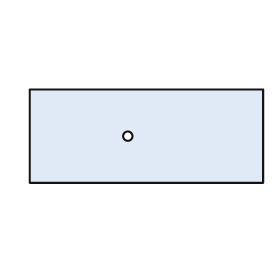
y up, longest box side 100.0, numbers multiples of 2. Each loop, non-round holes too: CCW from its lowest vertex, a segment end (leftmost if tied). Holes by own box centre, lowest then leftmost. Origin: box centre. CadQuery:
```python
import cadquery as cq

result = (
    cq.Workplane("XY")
    .moveTo(-50.0, -20.0)
    .lineTo(50.0, -20.0)
    .lineTo(50.0, 20.0)
    .lineTo(-50.0, 20.0)
    .close()
    .moveTo(-8.0, 0.0)
    .circle(2.0)
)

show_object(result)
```